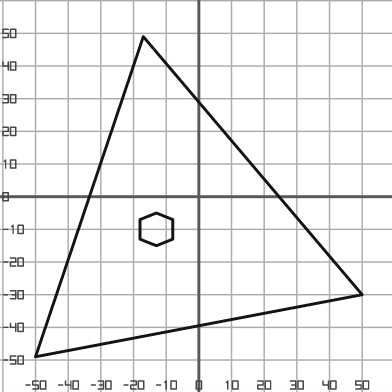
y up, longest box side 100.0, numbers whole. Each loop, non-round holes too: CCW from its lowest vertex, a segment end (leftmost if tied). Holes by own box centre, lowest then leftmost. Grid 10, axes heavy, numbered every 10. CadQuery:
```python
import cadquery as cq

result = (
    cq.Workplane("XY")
    .moveTo(-50.0, -49.0)
    .lineTo(50.0, -30.0)
    .lineTo(-17.0, 49.0)
    .close()
    .moveTo(-13.0, -15.0)
    .lineTo(-8.0, -13.0)
    .lineTo(-8.0, -7.0)
    .lineTo(-13.0, -5.0)
    .lineTo(-18.0, -7.0)
    .lineTo(-18.0, -13.0)
    .close()
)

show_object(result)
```